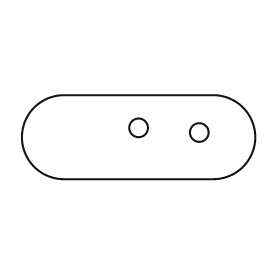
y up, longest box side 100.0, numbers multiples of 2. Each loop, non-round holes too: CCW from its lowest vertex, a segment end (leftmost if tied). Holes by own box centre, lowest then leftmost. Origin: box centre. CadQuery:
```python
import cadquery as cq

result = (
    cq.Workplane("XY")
    .moveTo(-32.0, -18.0)
    .lineTo(32.0, -18.0)
    .threePointArc((50.0, 0.0), (32.0, 18.0))
    .lineTo(-32.0, 18.0)
    .threePointArc((-50.0, 0.0), (-32.0, -18.0))
    .close()
    .moveTo(26.0, 2.0)
    .circle(4.0)
    .moveTo(0.0, 4.0)
    .circle(4.0)
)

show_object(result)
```